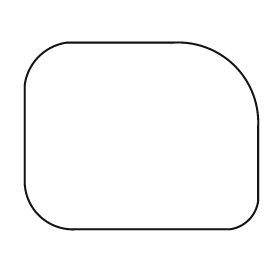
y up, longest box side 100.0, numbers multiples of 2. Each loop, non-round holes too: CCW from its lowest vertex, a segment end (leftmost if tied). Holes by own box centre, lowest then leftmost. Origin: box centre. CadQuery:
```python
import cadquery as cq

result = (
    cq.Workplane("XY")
    .moveTo(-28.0, -40.0)
    .lineTo(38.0, -40.0)
    .threePointArc((46.0, -36.0), (50.0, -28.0))
    .lineTo(50.0, 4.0)
    .threePointArc((40.0, 30.0), (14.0, 40.0))
    .lineTo(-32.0, 40.0)
    .threePointArc((-44.0, 34.0), (-50.0, 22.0))
    .lineTo(-50.0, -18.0)
    .threePointArc((-44.0, -34.0), (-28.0, -40.0))
    .close()
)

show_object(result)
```